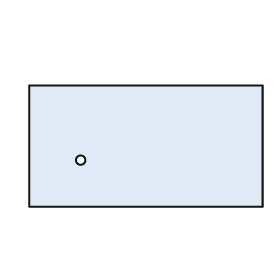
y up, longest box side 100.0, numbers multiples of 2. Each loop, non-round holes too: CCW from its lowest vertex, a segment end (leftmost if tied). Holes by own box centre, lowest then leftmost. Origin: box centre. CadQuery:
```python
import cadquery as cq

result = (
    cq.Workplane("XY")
    .moveTo(-50.0, -26.0)
    .lineTo(50.0, -26.0)
    .lineTo(50.0, 26.0)
    .lineTo(-50.0, 26.0)
    .close()
    .moveTo(-28.0, -6.0)
    .circle(2.0)
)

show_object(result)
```